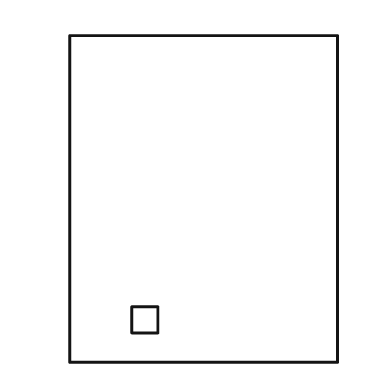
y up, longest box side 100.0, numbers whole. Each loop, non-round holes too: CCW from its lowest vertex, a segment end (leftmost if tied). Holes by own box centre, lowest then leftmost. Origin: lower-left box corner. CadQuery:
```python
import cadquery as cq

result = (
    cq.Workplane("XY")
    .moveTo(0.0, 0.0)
    .lineTo(82.0, 0.0)
    .lineTo(82.0, 100.0)
    .lineTo(0.0, 100.0)
    .close()
    .moveTo(19.0, 9.0)
    .lineTo(27.0, 9.0)
    .lineTo(27.0, 17.0)
    .lineTo(19.0, 17.0)
    .close()
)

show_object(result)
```